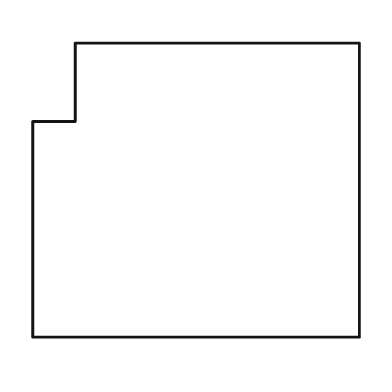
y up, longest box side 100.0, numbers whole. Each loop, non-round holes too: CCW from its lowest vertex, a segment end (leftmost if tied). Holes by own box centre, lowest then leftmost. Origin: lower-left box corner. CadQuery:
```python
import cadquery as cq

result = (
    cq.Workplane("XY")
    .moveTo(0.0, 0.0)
    .lineTo(100.0, 0.0)
    .lineTo(100.0, 90.0)
    .lineTo(13.0, 90.0)
    .lineTo(13.0, 66.0)
    .lineTo(0.0, 66.0)
    .close()
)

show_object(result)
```